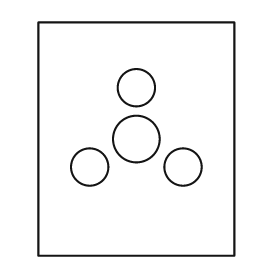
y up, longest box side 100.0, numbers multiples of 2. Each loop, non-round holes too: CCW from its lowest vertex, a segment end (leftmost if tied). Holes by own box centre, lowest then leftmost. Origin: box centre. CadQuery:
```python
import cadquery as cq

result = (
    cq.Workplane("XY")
    .moveTo(-42.0, -50.0)
    .lineTo(42.0, -50.0)
    .lineTo(42.0, 50.0)
    .lineTo(-42.0, 50.0)
    .close()
    .moveTo(-20.0, -12.0)
    .circle(8.0)
    .moveTo(20.0, -12.0)
    .circle(8.0)
    .moveTo(0.0, 0.0)
    .circle(10.0)
    .moveTo(0.0, 22.0)
    .circle(8.0)
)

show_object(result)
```